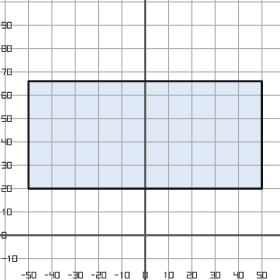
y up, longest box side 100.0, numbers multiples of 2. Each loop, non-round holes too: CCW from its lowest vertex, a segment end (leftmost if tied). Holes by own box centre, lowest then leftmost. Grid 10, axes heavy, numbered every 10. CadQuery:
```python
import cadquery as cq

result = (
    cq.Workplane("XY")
    .moveTo(-50.0, 20.0)
    .lineTo(50.0, 20.0)
    .lineTo(50.0, 66.0)
    .lineTo(-50.0, 66.0)
    .close()
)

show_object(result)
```